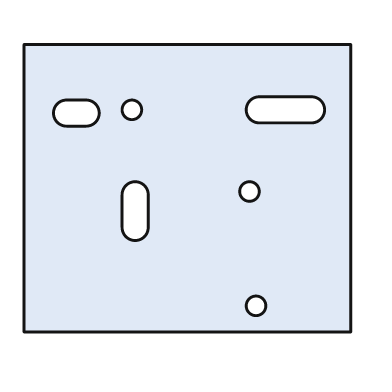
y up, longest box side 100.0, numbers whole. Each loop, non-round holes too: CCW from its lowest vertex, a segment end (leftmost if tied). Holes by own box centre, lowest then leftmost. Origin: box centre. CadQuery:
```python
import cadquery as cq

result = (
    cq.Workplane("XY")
    .moveTo(-50.0, -44.0)
    .lineTo(50.0, -44.0)
    .lineTo(50.0, 44.0)
    .lineTo(-50.0, 44.0)
    .close()
    .moveTo(21.0, -36.0)
    .circle(3.0)
    .moveTo(-20.0, -12.0)
    .threePointArc((-16.0, -16.0), (-12.0, -12.0))
    .lineTo(-12.0, -2.0)
    .threePointArc((-16.0, 2.0), (-20.0, -2.0))
    .close()
    .moveTo(19.0, -1.0)
    .circle(3.0)
    .moveTo(-37.0, 19.0)
    .lineTo(-31.0, 19.0)
    .threePointArc((-27.0, 23.0), (-31.0, 27.0))
    .lineTo(-37.0, 27.0)
    .threePointArc((-41.0, 23.0), (-37.0, 19.0))
    .close()
    .moveTo(-17.0, 24.0)
    .circle(3.0)
    .moveTo(22.0, 20.0)
    .lineTo(38.0, 20.0)
    .threePointArc((42.0, 24.0), (38.0, 28.0))
    .lineTo(22.0, 28.0)
    .threePointArc((18.0, 24.0), (22.0, 20.0))
    .close()
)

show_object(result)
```